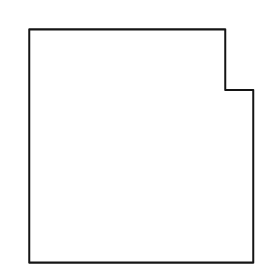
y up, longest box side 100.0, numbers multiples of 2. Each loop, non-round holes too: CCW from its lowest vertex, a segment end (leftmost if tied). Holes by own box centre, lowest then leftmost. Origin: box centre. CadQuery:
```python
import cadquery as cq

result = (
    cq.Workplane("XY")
    .moveTo(-48.0, -50.0)
    .lineTo(48.0, -50.0)
    .lineTo(48.0, 24.0)
    .lineTo(36.0, 24.0)
    .lineTo(36.0, 50.0)
    .lineTo(-48.0, 50.0)
    .close()
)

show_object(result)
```